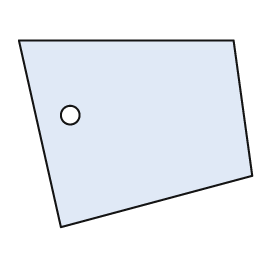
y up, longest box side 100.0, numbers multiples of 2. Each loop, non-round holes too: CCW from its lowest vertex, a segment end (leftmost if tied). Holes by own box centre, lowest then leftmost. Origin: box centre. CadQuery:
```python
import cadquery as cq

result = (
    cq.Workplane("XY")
    .moveTo(-32.0, -40.0)
    .lineTo(50.0, -18.0)
    .lineTo(42.0, 40.0)
    .lineTo(-50.0, 40.0)
    .close()
    .moveTo(-28.0, 8.0)
    .circle(4.0)
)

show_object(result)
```